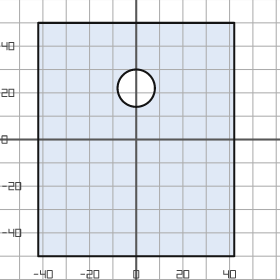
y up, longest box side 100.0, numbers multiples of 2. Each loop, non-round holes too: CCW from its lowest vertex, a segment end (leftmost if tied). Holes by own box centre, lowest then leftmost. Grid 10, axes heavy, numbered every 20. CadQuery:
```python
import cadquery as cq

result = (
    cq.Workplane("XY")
    .moveTo(-42.0, -50.0)
    .lineTo(42.0, -50.0)
    .lineTo(42.0, 50.0)
    .lineTo(-42.0, 50.0)
    .close()
    .moveTo(0.0, 22.0)
    .circle(8.0)
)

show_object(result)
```